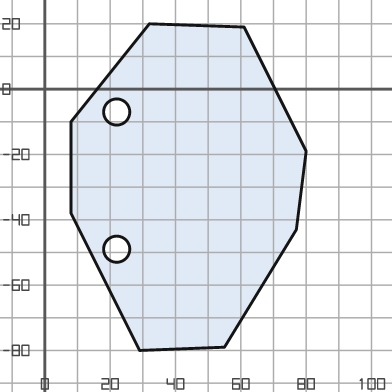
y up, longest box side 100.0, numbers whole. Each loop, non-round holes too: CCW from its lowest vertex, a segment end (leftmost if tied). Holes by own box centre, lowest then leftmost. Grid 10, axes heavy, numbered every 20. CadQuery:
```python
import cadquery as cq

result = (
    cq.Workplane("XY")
    .moveTo(29.0, -80.0)
    .lineTo(55.0, -79.0)
    .lineTo(77.0, -43.0)
    .lineTo(80.0, -19.0)
    .lineTo(61.0, 19.0)
    .lineTo(32.0, 20.0)
    .lineTo(8.0, -10.0)
    .lineTo(8.0, -38.0)
    .close()
    .moveTo(22.0, -49.0)
    .circle(4.0)
    .moveTo(22.0, -7.0)
    .circle(4.0)
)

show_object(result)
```